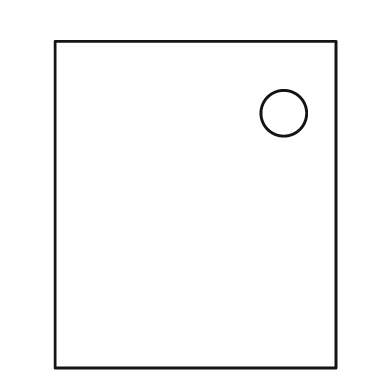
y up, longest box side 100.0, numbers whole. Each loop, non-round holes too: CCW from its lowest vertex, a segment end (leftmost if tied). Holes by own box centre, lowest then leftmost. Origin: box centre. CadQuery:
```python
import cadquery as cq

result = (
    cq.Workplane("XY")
    .moveTo(-43.0, -50.0)
    .lineTo(43.0, -50.0)
    .lineTo(43.0, 50.0)
    .lineTo(-43.0, 50.0)
    .close()
    .moveTo(27.0, 28.0)
    .circle(7.0)
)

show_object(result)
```